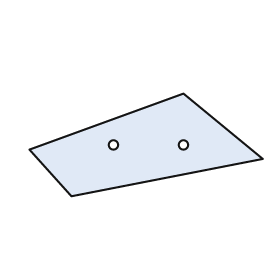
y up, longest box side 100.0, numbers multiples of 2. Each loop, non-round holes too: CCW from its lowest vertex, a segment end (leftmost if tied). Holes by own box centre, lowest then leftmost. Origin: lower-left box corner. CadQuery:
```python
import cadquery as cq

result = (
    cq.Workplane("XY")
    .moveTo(18.0, 0.0)
    .lineTo(100.0, 16.0)
    .lineTo(66.0, 44.0)
    .lineTo(0.0, 20.0)
    .close()
    .moveTo(36.0, 22.0)
    .circle(2.0)
    .moveTo(66.0, 22.0)
    .circle(2.0)
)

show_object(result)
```